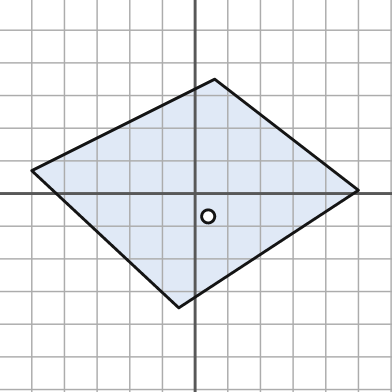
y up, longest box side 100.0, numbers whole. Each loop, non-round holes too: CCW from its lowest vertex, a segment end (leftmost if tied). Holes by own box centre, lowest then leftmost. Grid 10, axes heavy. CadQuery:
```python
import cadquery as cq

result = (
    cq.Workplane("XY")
    .moveTo(-5.0, -35.0)
    .lineTo(50.0, 1.0)
    .lineTo(6.0, 35.0)
    .lineTo(-50.0, 7.0)
    .close()
    .moveTo(4.0, -7.0)
    .circle(2.0)
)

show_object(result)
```